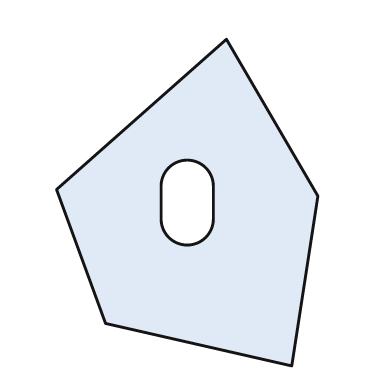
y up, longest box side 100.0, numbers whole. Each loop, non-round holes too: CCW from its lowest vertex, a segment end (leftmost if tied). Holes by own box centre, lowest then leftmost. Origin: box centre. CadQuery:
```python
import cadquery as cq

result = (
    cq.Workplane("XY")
    .moveTo(32.0, -50.0)
    .lineTo(40.0, 2.0)
    .lineTo(12.0, 50.0)
    .lineTo(-40.0, 4.0)
    .lineTo(-25.0, -37.0)
    .close()
    .moveTo(-8.0, -5.0)
    .threePointArc((0.0, -13.0), (8.0, -5.0))
    .lineTo(8.0, 5.0)
    .threePointArc((0.0, 13.0), (-8.0, 5.0))
    .close()
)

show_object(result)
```